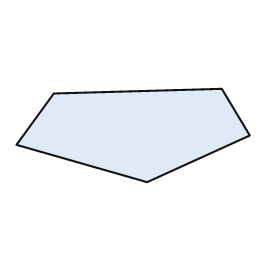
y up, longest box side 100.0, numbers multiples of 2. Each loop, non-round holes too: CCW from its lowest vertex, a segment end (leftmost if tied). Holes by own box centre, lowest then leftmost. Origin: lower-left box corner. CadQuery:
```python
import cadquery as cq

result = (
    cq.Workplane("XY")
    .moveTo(56.0, 0.0)
    .lineTo(100.0, 20.0)
    .lineTo(88.0, 40.0)
    .lineTo(16.0, 38.0)
    .lineTo(0.0, 16.0)
    .close()
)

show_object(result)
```